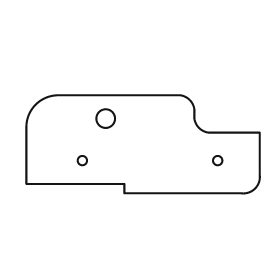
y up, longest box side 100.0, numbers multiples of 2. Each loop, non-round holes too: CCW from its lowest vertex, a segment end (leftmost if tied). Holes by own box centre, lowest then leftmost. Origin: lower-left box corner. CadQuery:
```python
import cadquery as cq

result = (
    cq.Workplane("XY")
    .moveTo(42.0, 0.0)
    .lineTo(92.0, 0.0)
    .threePointArc((98.0, 2.0), (100.0, 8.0))
    .lineTo(100.0, 26.0)
    .lineTo(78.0, 26.0)
    .threePointArc((74.0, 28.0), (72.0, 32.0))
    .lineTo(72.0, 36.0)
    .threePointArc((70.0, 40.0), (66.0, 42.0))
    .lineTo(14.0, 42.0)
    .threePointArc((4.0, 38.0), (0.0, 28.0))
    .lineTo(0.0, 4.0)
    .lineTo(42.0, 4.0)
    .close()
    .moveTo(24.0, 14.0)
    .circle(2.0)
    .moveTo(82.0, 14.0)
    .circle(2.0)
    .moveTo(34.0, 32.0)
    .circle(4.0)
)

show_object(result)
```